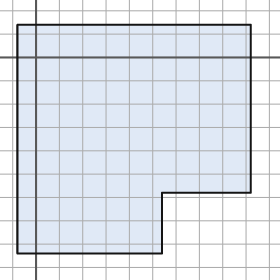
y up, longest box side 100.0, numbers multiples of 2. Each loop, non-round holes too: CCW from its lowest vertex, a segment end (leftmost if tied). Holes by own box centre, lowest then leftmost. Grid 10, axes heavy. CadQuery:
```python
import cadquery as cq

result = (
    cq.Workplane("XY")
    .moveTo(-8.0, -84.0)
    .lineTo(54.0, -84.0)
    .lineTo(54.0, -58.0)
    .lineTo(92.0, -58.0)
    .lineTo(92.0, 14.0)
    .lineTo(-8.0, 14.0)
    .close()
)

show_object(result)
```